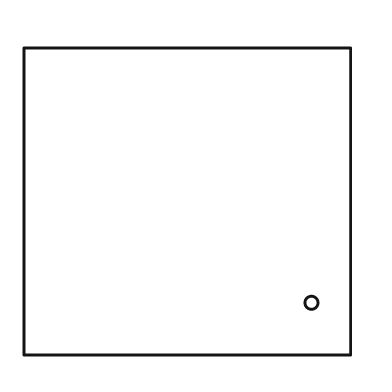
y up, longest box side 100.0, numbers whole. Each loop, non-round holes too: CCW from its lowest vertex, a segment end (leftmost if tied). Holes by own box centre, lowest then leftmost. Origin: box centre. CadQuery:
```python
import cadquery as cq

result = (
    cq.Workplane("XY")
    .moveTo(-50.0, -47.0)
    .lineTo(50.0, -47.0)
    .lineTo(50.0, 47.0)
    .lineTo(-50.0, 47.0)
    .close()
    .moveTo(38.0, -31.0)
    .circle(2.0)
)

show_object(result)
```